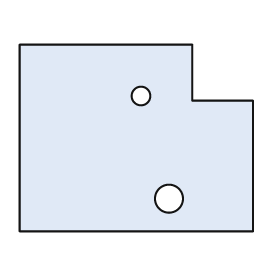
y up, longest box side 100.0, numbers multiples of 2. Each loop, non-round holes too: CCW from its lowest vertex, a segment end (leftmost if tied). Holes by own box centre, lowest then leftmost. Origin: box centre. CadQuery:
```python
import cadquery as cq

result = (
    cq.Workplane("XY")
    .moveTo(-50.0, -40.0)
    .lineTo(50.0, -40.0)
    .lineTo(50.0, 16.0)
    .lineTo(24.0, 16.0)
    .lineTo(24.0, 40.0)
    .lineTo(-50.0, 40.0)
    .close()
    .moveTo(14.0, -26.0)
    .circle(6.0)
    .moveTo(2.0, 18.0)
    .circle(4.0)
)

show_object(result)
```